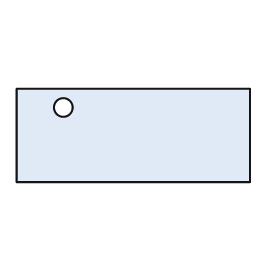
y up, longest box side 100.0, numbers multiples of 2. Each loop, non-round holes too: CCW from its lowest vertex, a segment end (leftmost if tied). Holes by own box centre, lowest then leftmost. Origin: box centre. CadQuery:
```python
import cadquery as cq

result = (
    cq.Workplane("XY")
    .moveTo(-50.0, -20.0)
    .lineTo(50.0, -20.0)
    .lineTo(50.0, 20.0)
    .lineTo(-50.0, 20.0)
    .close()
    .moveTo(-30.0, 12.0)
    .circle(4.0)
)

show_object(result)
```